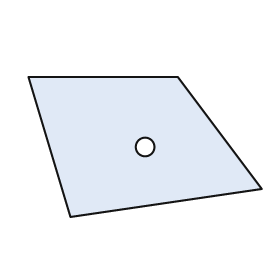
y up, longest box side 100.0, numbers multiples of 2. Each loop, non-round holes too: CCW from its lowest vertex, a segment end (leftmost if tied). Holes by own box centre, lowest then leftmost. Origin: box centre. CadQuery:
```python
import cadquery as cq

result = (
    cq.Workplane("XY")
    .moveTo(-32.0, -30.0)
    .lineTo(50.0, -18.0)
    .lineTo(14.0, 30.0)
    .lineTo(-50.0, 30.0)
    .close()
    .moveTo(0.0, 0.0)
    .circle(4.0)
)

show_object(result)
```